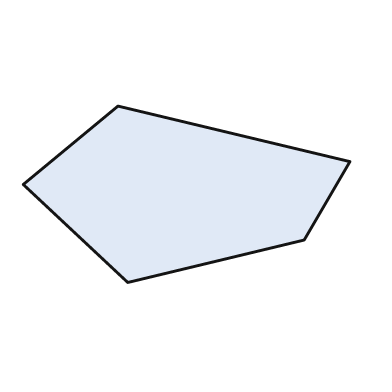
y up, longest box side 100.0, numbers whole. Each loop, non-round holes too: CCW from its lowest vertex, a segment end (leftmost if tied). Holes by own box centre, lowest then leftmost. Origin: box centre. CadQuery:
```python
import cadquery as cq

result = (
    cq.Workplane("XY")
    .moveTo(-18.0, -27.0)
    .lineTo(36.0, -14.0)
    .lineTo(50.0, 10.0)
    .lineTo(-21.0, 27.0)
    .lineTo(-50.0, 3.0)
    .close()
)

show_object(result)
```